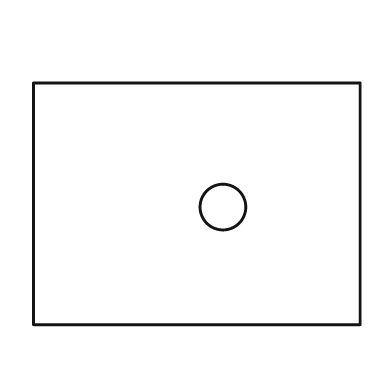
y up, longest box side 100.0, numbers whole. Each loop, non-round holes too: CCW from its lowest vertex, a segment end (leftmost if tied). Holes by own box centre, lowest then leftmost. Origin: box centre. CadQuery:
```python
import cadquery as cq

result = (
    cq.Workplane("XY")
    .moveTo(-50.0, -37.0)
    .lineTo(50.0, -37.0)
    .lineTo(50.0, 37.0)
    .lineTo(-50.0, 37.0)
    .close()
    .moveTo(8.0, -1.0)
    .circle(7.0)
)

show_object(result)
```